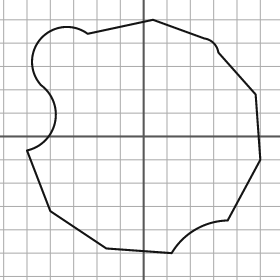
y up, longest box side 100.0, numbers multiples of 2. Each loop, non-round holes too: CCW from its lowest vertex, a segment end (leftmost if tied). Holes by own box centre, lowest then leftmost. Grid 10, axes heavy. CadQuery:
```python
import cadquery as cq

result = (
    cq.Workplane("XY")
    .moveTo(12.0, -50.0)
    .threePointArc((22.0, -40.0), (36.0, -36.0))
    .lineTo(50.0, -10.0)
    .lineTo(48.0, 18.0)
    .lineTo(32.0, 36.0)
    .threePointArc((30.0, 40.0), (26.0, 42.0))
    .lineTo(4.0, 50.0)
    .lineTo(-24.0, 44.0)
    .threePointArc((-44.0, 42.0), (-44.0, 22.0))
    .threePointArc((-38.0, 6.0), (-50.0, -6.0))
    .lineTo(-40.0, -32.0)
    .lineTo(-16.0, -48.0)
    .close()
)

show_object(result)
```